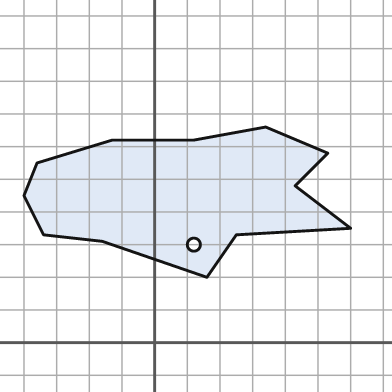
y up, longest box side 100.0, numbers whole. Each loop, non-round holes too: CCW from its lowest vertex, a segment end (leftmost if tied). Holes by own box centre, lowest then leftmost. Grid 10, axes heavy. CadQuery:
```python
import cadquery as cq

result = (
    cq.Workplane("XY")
    .moveTo(16.0, 20.0)
    .lineTo(25.0, 33.0)
    .lineTo(60.0, 35.0)
    .lineTo(43.0, 48.0)
    .lineTo(53.0, 58.0)
    .lineTo(34.0, 66.0)
    .lineTo(12.0, 62.0)
    .lineTo(-13.0, 62.0)
    .lineTo(-36.0, 55.0)
    .lineTo(-40.0, 45.0)
    .lineTo(-34.0, 33.0)
    .lineTo(-16.0, 31.0)
    .close()
    .moveTo(12.0, 30.0)
    .circle(2.0)
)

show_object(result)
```